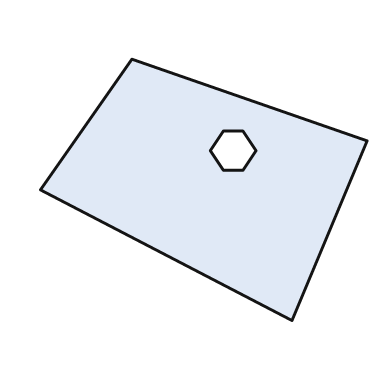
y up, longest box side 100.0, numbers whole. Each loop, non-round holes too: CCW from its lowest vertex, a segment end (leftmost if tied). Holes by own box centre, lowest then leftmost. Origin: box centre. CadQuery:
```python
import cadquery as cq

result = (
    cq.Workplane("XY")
    .moveTo(27.0, -40.0)
    .lineTo(50.0, 15.0)
    .lineTo(-22.0, 40.0)
    .lineTo(-50.0, 0.0)
    .close()
    .moveTo(6.0, 6.0)
    .lineTo(12.0, 6.0)
    .lineTo(16.0, 12.0)
    .lineTo(12.0, 18.0)
    .lineTo(6.0, 18.0)
    .lineTo(2.0, 12.0)
    .close()
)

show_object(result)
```